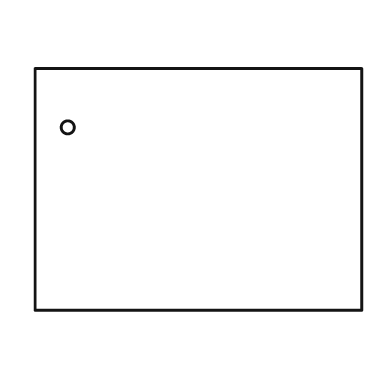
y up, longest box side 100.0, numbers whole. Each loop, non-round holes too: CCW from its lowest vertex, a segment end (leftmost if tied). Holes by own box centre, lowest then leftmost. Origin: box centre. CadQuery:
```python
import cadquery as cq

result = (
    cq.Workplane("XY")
    .moveTo(-50.0, -37.0)
    .lineTo(50.0, -37.0)
    .lineTo(50.0, 37.0)
    .lineTo(-50.0, 37.0)
    .close()
    .moveTo(-40.0, 19.0)
    .circle(2.0)
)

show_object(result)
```